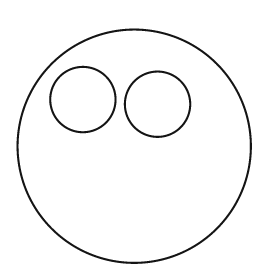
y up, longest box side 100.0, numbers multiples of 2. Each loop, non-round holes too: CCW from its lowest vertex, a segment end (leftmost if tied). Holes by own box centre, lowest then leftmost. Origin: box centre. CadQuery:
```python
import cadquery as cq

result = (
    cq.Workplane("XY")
    .moveTo(0.0, 0.0)
    .circle(50.0)
    .moveTo(10.0, 18.0)
    .circle(14.0)
    .moveTo(-22.0, 20.0)
    .circle(14.0)
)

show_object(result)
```